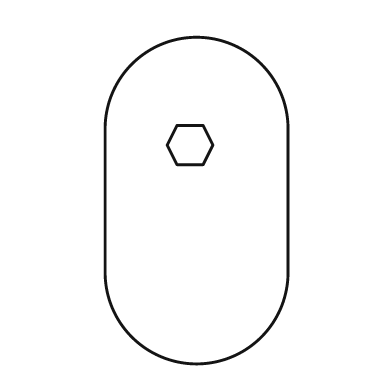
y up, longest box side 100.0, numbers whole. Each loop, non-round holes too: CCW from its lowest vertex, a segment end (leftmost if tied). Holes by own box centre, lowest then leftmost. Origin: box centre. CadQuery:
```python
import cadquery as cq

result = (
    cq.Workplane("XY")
    .moveTo(-28.0, -22.0)
    .threePointArc((0.0, -50.0), (28.0, -22.0))
    .lineTo(28.0, 22.0)
    .threePointArc((0.0, 50.0), (-28.0, 22.0))
    .close()
    .moveTo(-6.0, 11.0)
    .lineTo(2.0, 11.0)
    .lineTo(5.0, 17.0)
    .lineTo(2.0, 23.0)
    .lineTo(-6.0, 23.0)
    .lineTo(-9.0, 17.0)
    .close()
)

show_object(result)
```